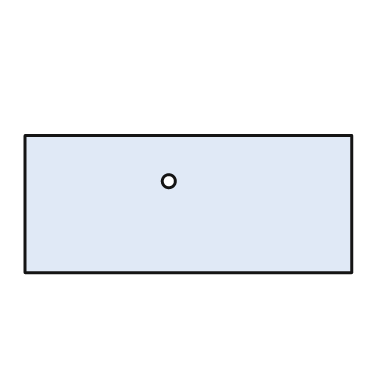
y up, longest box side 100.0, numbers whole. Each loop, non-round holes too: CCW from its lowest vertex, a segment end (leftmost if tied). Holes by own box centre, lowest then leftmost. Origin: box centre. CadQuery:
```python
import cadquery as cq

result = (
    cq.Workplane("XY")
    .moveTo(-50.0, -21.0)
    .lineTo(50.0, -21.0)
    .lineTo(50.0, 21.0)
    .lineTo(-50.0, 21.0)
    .close()
    .moveTo(-6.0, 7.0)
    .circle(2.0)
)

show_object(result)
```